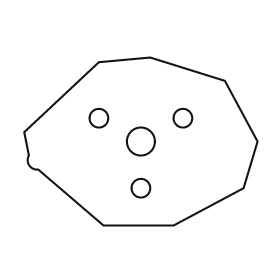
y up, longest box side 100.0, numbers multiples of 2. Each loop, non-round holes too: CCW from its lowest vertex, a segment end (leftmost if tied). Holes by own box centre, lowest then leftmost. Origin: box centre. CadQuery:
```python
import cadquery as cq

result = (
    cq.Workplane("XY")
    .moveTo(-16.0, -36.0)
    .lineTo(14.0, -36.0)
    .lineTo(44.0, -20.0)
    .lineTo(50.0, 0.0)
    .lineTo(36.0, 26.0)
    .lineTo(4.0, 36.0)
    .lineTo(-18.0, 34.0)
    .lineTo(-50.0, 4.0)
    .lineTo(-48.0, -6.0)
    .threePointArc((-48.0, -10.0), (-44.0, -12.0))
    .close()
    .moveTo(0.0, -20.0)
    .circle(4.0)
    .moveTo(0.0, 0.0)
    .circle(6.0)
    .moveTo(-18.0, 10.0)
    .circle(4.0)
    .moveTo(18.0, 10.0)
    .circle(4.0)
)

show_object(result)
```